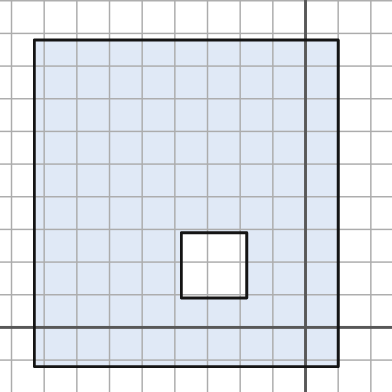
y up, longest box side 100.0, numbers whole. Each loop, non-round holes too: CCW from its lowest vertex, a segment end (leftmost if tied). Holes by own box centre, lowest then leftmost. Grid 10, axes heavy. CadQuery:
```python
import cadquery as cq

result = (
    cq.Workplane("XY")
    .moveTo(-83.0, -12.0)
    .lineTo(10.0, -12.0)
    .lineTo(10.0, 88.0)
    .lineTo(-83.0, 88.0)
    .close()
    .moveTo(-38.0, 9.0)
    .lineTo(-18.0, 9.0)
    .lineTo(-18.0, 29.0)
    .lineTo(-38.0, 29.0)
    .close()
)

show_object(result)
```